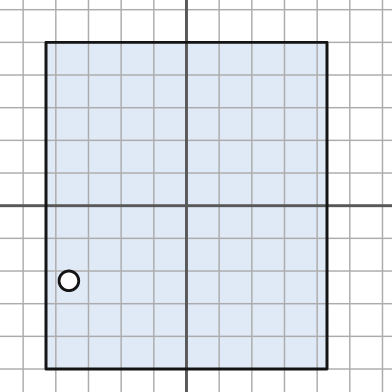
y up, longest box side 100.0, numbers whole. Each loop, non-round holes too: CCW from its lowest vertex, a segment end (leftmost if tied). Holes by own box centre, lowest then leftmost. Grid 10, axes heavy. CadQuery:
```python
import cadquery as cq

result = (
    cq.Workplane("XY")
    .moveTo(-43.0, -50.0)
    .lineTo(43.0, -50.0)
    .lineTo(43.0, 50.0)
    .lineTo(-43.0, 50.0)
    .close()
    .moveTo(-36.0, -23.0)
    .circle(3.0)
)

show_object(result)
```